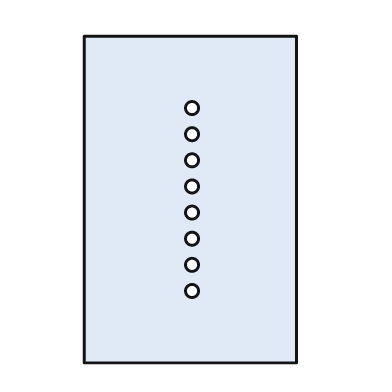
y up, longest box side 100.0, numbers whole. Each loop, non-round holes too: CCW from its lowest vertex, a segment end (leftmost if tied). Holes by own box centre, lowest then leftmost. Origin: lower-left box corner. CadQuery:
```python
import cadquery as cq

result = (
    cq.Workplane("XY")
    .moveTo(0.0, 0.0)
    .lineTo(65.0, 0.0)
    .lineTo(65.0, 100.0)
    .lineTo(0.0, 100.0)
    .close()
    .moveTo(33.0, 22.0)
    .circle(2.0)
    .moveTo(33.0, 30.0)
    .circle(2.0)
    .moveTo(33.0, 38.0)
    .circle(2.0)
    .moveTo(33.0, 46.0)
    .circle(2.0)
    .moveTo(33.0, 54.0)
    .circle(2.0)
    .moveTo(33.0, 62.0)
    .circle(2.0)
    .moveTo(33.0, 70.0)
    .circle(2.0)
    .moveTo(33.0, 78.0)
    .circle(2.0)
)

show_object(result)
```